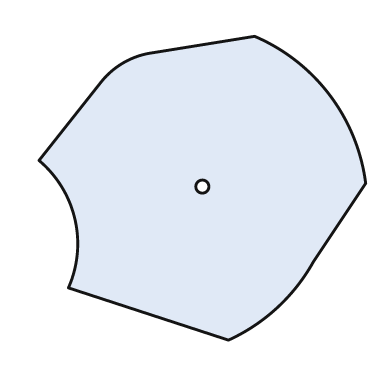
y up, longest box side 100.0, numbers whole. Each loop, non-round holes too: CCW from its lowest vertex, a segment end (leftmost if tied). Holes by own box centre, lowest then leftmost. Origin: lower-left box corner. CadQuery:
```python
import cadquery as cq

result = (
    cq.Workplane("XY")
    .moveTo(58.0, 0.0)
    .threePointArc((73.0, 10.0), (84.0, 24.0))
    .lineTo(100.0, 48.0)
    .threePointArc((89.0, 75.0), (66.0, 93.0))
    .lineTo(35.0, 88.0)
    .threePointArc((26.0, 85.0), (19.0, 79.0))
    .lineTo(0.0, 55.0)
    .threePointArc((11.0, 37.0), (9.0, 16.0))
    .close()
    .moveTo(50.0, 47.0)
    .circle(2.0)
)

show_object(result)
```